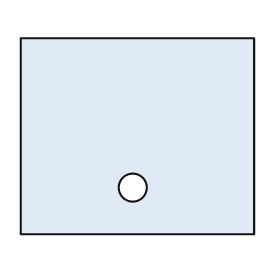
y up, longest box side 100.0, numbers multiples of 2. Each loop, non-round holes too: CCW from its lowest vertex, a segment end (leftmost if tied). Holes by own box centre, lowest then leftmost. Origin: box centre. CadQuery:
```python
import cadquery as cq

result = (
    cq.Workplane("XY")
    .moveTo(-50.0, -42.0)
    .lineTo(50.0, -42.0)
    .lineTo(50.0, 42.0)
    .lineTo(-50.0, 42.0)
    .close()
    .moveTo(-2.0, -22.0)
    .circle(6.0)
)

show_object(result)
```